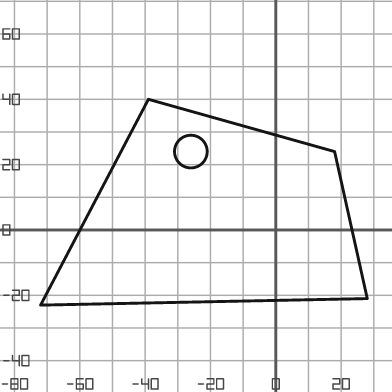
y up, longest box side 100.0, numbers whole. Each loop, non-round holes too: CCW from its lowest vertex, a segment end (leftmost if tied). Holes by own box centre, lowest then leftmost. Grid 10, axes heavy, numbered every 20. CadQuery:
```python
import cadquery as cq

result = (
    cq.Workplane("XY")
    .moveTo(-72.0, -23.0)
    .lineTo(28.0, -21.0)
    .lineTo(18.0, 24.0)
    .lineTo(-39.0, 40.0)
    .close()
    .moveTo(-26.0, 24.0)
    .circle(5.0)
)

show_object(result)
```